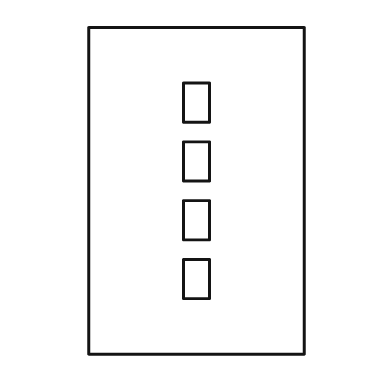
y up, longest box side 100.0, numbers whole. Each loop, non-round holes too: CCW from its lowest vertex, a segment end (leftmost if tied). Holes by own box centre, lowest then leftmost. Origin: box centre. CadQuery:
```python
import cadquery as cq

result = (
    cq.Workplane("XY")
    .moveTo(-33.0, -50.0)
    .lineTo(33.0, -50.0)
    .lineTo(33.0, 50.0)
    .lineTo(-33.0, 50.0)
    .close()
    .moveTo(-4.0, -33.0)
    .lineTo(4.0, -33.0)
    .lineTo(4.0, -21.0)
    .lineTo(-4.0, -21.0)
    .close()
    .moveTo(-4.0, -15.0)
    .lineTo(4.0, -15.0)
    .lineTo(4.0, -3.0)
    .lineTo(-4.0, -3.0)
    .close()
    .moveTo(-4.0, 3.0)
    .lineTo(4.0, 3.0)
    .lineTo(4.0, 15.0)
    .lineTo(-4.0, 15.0)
    .close()
    .moveTo(-4.0, 21.0)
    .lineTo(4.0, 21.0)
    .lineTo(4.0, 33.0)
    .lineTo(-4.0, 33.0)
    .close()
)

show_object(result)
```